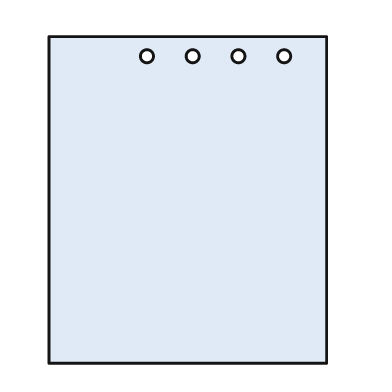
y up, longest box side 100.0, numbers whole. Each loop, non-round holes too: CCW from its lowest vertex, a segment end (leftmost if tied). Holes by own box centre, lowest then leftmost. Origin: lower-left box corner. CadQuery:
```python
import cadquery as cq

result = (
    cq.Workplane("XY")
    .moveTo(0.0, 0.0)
    .lineTo(85.0, 0.0)
    .lineTo(85.0, 100.0)
    .lineTo(0.0, 100.0)
    .close()
    .moveTo(30.0, 94.0)
    .circle(2.0)
    .moveTo(44.0, 94.0)
    .circle(2.0)
    .moveTo(58.0, 94.0)
    .circle(2.0)
    .moveTo(72.0, 94.0)
    .circle(2.0)
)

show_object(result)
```